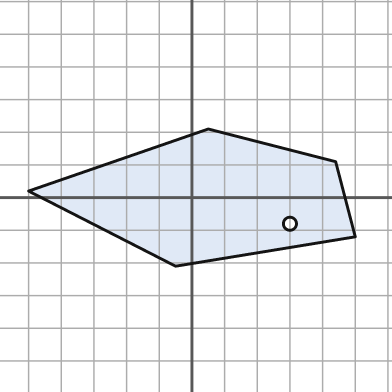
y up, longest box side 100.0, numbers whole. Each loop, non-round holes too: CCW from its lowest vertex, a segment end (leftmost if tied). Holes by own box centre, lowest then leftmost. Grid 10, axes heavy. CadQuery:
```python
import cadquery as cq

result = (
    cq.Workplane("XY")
    .moveTo(-5.0, -21.0)
    .lineTo(50.0, -12.0)
    .lineTo(44.0, 11.0)
    .lineTo(5.0, 21.0)
    .lineTo(-50.0, 2.0)
    .close()
    .moveTo(30.0, -8.0)
    .circle(2.0)
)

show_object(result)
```